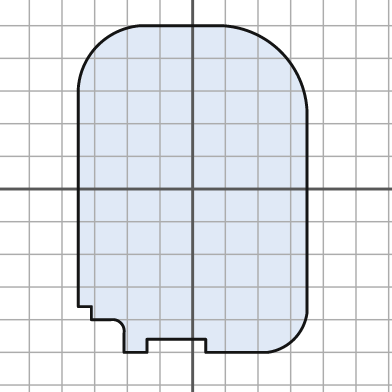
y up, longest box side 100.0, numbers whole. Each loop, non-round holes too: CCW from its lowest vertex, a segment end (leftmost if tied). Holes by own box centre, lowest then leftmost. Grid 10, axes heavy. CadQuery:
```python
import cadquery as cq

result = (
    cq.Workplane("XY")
    .moveTo(-21.0, -50.0)
    .lineTo(-14.0, -50.0)
    .lineTo(-14.0, -46.0)
    .lineTo(4.0, -46.0)
    .lineTo(4.0, -50.0)
    .lineTo(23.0, -50.0)
    .threePointArc((31.0, -46.0), (35.0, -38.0))
    .lineTo(35.0, 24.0)
    .threePointArc((27.0, 42.0), (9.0, 50.0))
    .lineTo(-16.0, 50.0)
    .threePointArc((-29.0, 44.0), (-35.0, 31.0))
    .lineTo(-35.0, -36.0)
    .lineTo(-31.0, -36.0)
    .lineTo(-31.0, -40.0)
    .lineTo(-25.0, -40.0)
    .threePointArc((-22.0, -41.0), (-21.0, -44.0))
    .close()
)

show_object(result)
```